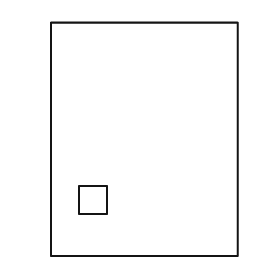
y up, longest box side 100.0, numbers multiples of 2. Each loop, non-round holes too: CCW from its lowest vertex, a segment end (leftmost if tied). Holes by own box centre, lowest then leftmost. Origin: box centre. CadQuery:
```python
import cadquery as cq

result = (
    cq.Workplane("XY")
    .moveTo(-40.0, -50.0)
    .lineTo(40.0, -50.0)
    .lineTo(40.0, 50.0)
    .lineTo(-40.0, 50.0)
    .close()
    .moveTo(-28.0, -32.0)
    .lineTo(-16.0, -32.0)
    .lineTo(-16.0, -20.0)
    .lineTo(-28.0, -20.0)
    .close()
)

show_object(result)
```